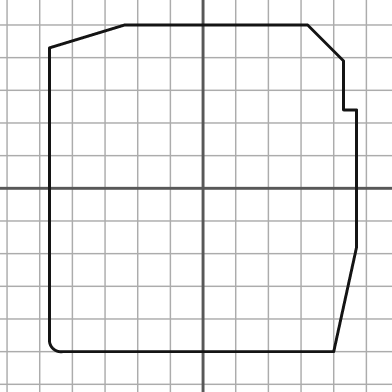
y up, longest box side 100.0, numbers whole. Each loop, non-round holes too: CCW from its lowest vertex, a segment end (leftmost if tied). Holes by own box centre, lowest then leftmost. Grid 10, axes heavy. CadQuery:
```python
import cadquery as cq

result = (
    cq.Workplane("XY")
    .moveTo(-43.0, -50.0)
    .lineTo(40.0, -50.0)
    .lineTo(47.0, -18.0)
    .lineTo(47.0, 24.0)
    .lineTo(43.0, 24.0)
    .lineTo(43.0, 39.0)
    .lineTo(32.0, 50.0)
    .lineTo(-24.0, 50.0)
    .lineTo(-47.0, 43.0)
    .lineTo(-47.0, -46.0)
    .threePointArc((-46.0, -49.0), (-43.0, -50.0))
    .close()
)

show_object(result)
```